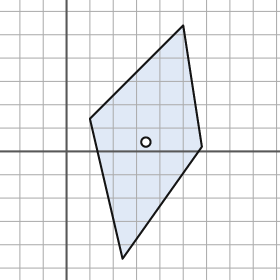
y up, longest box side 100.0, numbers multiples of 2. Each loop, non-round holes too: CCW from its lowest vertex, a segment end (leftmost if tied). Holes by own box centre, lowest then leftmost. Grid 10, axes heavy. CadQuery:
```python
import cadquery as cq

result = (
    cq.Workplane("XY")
    .moveTo(24.0, -46.0)
    .lineTo(58.0, 2.0)
    .lineTo(50.0, 54.0)
    .lineTo(10.0, 14.0)
    .close()
    .moveTo(34.0, 4.0)
    .circle(2.0)
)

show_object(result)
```